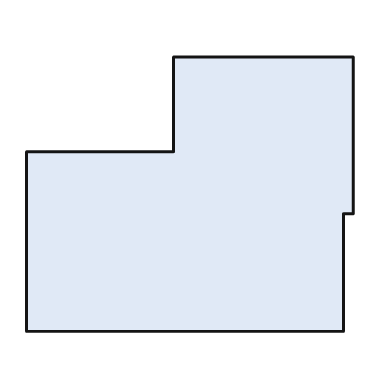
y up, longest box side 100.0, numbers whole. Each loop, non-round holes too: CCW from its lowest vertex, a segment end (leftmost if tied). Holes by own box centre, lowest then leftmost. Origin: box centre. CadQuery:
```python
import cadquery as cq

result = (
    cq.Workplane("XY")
    .moveTo(-50.0, -42.0)
    .lineTo(47.0, -42.0)
    .lineTo(47.0, -6.0)
    .lineTo(50.0, -6.0)
    .lineTo(50.0, 42.0)
    .lineTo(-5.0, 42.0)
    .lineTo(-5.0, 13.0)
    .lineTo(-50.0, 13.0)
    .close()
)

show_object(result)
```